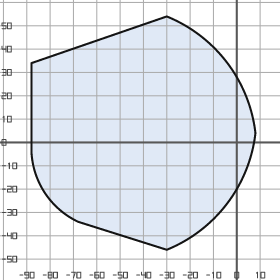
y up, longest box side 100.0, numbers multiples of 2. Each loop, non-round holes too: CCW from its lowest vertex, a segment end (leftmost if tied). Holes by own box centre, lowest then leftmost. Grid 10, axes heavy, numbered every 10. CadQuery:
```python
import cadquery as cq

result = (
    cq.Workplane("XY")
    .moveTo(-30.0, -46.0)
    .threePointArc((-4.0, -26.0), (8.0, 4.0))
    .threePointArc((-4.0, 34.0), (-30.0, 54.0))
    .lineTo(-88.0, 34.0)
    .lineTo(-88.0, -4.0)
    .threePointArc((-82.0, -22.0), (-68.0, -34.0))
    .close()
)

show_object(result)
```